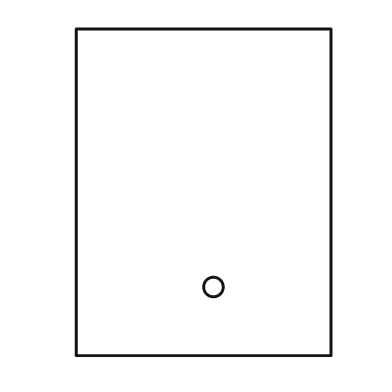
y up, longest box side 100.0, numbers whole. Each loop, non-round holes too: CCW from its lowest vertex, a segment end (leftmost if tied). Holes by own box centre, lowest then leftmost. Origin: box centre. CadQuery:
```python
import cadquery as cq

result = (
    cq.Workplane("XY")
    .moveTo(-39.0, -50.0)
    .lineTo(39.0, -50.0)
    .lineTo(39.0, 50.0)
    .lineTo(-39.0, 50.0)
    .close()
    .moveTo(3.0, -29.0)
    .circle(3.0)
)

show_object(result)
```